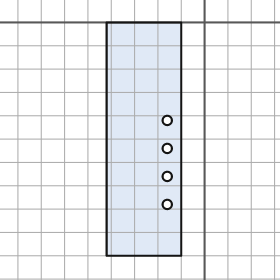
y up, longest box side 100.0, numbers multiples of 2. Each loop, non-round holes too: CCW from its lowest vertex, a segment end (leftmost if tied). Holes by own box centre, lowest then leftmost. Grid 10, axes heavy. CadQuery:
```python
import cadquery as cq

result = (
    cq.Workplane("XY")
    .moveTo(-42.0, -100.0)
    .lineTo(-10.0, -100.0)
    .lineTo(-10.0, 0.0)
    .lineTo(-42.0, 0.0)
    .close()
    .moveTo(-16.0, -78.0)
    .circle(2.0)
    .moveTo(-16.0, -66.0)
    .circle(2.0)
    .moveTo(-16.0, -54.0)
    .circle(2.0)
    .moveTo(-16.0, -42.0)
    .circle(2.0)
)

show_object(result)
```